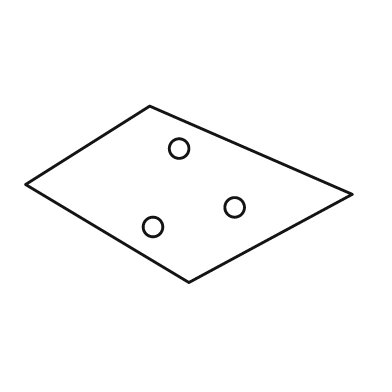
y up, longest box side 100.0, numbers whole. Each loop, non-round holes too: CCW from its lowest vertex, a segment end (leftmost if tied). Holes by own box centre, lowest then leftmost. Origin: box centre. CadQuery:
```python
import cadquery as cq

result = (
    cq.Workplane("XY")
    .moveTo(0.0, -27.0)
    .lineTo(50.0, 0.0)
    .lineTo(-12.0, 27.0)
    .lineTo(-50.0, 3.0)
    .close()
    .moveTo(-11.0, -10.0)
    .circle(3.0)
    .moveTo(14.0, -4.0)
    .circle(3.0)
    .moveTo(-3.0, 14.0)
    .circle(3.0)
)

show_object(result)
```